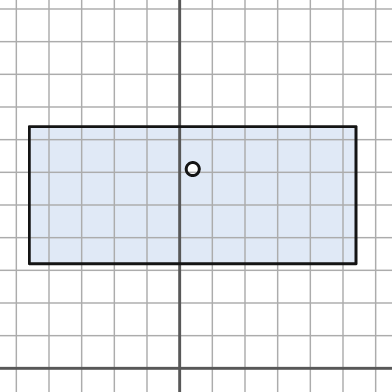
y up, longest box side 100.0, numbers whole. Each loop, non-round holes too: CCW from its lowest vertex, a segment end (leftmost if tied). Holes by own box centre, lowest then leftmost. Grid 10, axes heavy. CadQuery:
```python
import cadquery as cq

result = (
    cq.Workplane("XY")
    .moveTo(-46.0, 32.0)
    .lineTo(54.0, 32.0)
    .lineTo(54.0, 74.0)
    .lineTo(-46.0, 74.0)
    .close()
    .moveTo(4.0, 61.0)
    .circle(2.0)
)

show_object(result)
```